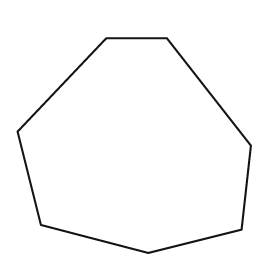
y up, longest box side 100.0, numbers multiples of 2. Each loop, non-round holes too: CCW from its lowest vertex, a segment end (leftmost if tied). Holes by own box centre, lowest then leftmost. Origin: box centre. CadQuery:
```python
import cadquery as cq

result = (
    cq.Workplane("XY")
    .moveTo(6.0, -46.0)
    .lineTo(46.0, -36.0)
    .lineTo(50.0, 0.0)
    .lineTo(14.0, 46.0)
    .lineTo(-12.0, 46.0)
    .lineTo(-50.0, 6.0)
    .lineTo(-40.0, -34.0)
    .close()
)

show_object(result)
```